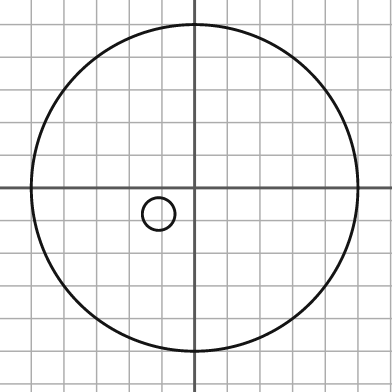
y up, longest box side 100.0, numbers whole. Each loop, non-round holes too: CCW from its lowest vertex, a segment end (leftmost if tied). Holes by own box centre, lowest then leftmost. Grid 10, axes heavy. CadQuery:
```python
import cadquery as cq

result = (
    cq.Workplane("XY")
    .moveTo(0.0, 0.0)
    .circle(50.0)
    .moveTo(-11.0, -8.0)
    .circle(5.0)
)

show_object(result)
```